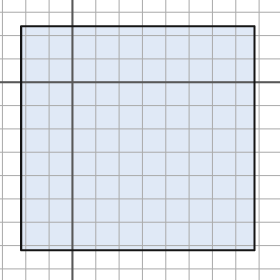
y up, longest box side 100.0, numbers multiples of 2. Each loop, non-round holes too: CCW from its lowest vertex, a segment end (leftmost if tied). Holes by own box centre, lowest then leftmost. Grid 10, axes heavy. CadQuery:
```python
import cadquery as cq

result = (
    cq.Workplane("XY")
    .moveTo(-22.0, -72.0)
    .lineTo(78.0, -72.0)
    .lineTo(78.0, 24.0)
    .lineTo(-22.0, 24.0)
    .close()
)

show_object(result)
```